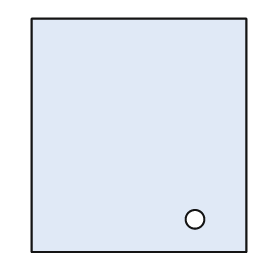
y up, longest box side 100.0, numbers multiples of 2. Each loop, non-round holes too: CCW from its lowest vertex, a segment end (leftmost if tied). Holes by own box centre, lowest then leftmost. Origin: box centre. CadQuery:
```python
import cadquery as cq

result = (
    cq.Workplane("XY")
    .moveTo(-46.0, -50.0)
    .lineTo(46.0, -50.0)
    .lineTo(46.0, 50.0)
    .lineTo(-46.0, 50.0)
    .close()
    .moveTo(24.0, -36.0)
    .circle(4.0)
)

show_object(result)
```